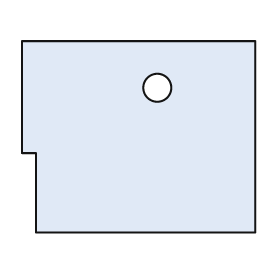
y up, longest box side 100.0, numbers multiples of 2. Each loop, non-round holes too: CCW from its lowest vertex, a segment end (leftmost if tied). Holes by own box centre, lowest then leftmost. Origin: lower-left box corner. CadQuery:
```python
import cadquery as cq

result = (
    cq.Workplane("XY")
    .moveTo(6.0, 0.0)
    .lineTo(100.0, 0.0)
    .lineTo(100.0, 82.0)
    .lineTo(0.0, 82.0)
    .lineTo(0.0, 34.0)
    .lineTo(6.0, 34.0)
    .close()
    .moveTo(58.0, 62.0)
    .circle(6.0)
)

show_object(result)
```